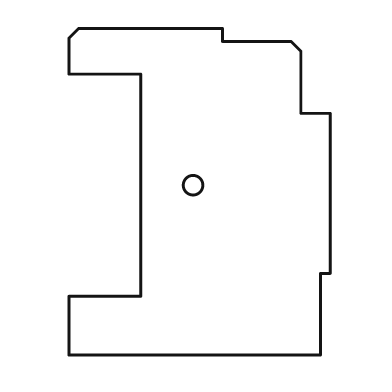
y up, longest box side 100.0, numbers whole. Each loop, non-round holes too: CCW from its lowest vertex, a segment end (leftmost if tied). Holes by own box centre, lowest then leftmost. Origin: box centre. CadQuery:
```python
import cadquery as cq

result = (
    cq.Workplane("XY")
    .moveTo(-40.0, -50.0)
    .lineTo(37.0, -50.0)
    .lineTo(37.0, -25.0)
    .lineTo(40.0, -25.0)
    .lineTo(40.0, 24.0)
    .lineTo(31.0, 24.0)
    .lineTo(31.0, 43.0)
    .lineTo(28.0, 46.0)
    .lineTo(7.0, 46.0)
    .lineTo(7.0, 50.0)
    .lineTo(-37.0, 50.0)
    .lineTo(-40.0, 47.0)
    .lineTo(-40.0, 36.0)
    .lineTo(-18.0, 36.0)
    .lineTo(-18.0, -32.0)
    .lineTo(-40.0, -32.0)
    .close()
    .moveTo(-2.0, 2.0)
    .circle(3.0)
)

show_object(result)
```